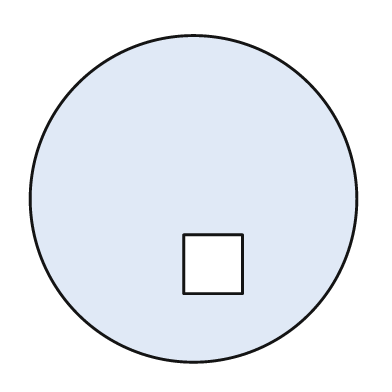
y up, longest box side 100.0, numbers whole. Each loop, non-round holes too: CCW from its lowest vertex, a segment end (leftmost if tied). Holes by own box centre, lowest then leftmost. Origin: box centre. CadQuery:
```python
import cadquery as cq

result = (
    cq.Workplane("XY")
    .moveTo(0.0, 0.0)
    .circle(50.0)
    .moveTo(-3.0, -29.0)
    .lineTo(15.0, -29.0)
    .lineTo(15.0, -11.0)
    .lineTo(-3.0, -11.0)
    .close()
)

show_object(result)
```